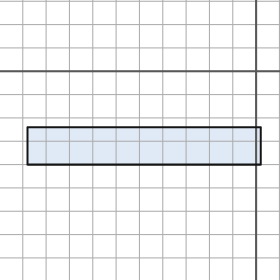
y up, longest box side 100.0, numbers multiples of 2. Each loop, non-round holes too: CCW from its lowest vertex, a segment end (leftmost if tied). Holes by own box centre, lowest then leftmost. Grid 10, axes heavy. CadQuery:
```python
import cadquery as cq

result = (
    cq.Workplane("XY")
    .moveTo(-98.0, -40.0)
    .lineTo(2.0, -40.0)
    .lineTo(2.0, -24.0)
    .lineTo(-98.0, -24.0)
    .close()
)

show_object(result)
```